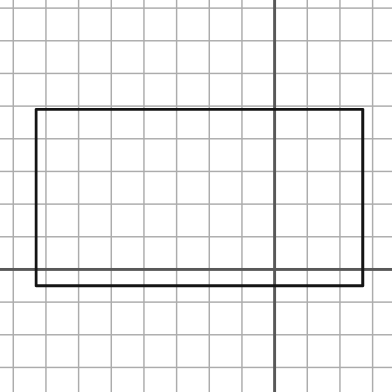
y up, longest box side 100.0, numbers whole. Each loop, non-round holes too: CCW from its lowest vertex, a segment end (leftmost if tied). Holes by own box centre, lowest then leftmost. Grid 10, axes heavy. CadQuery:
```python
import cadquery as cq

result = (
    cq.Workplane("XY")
    .moveTo(-73.0, -5.0)
    .lineTo(27.0, -5.0)
    .lineTo(27.0, 49.0)
    .lineTo(-73.0, 49.0)
    .close()
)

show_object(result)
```